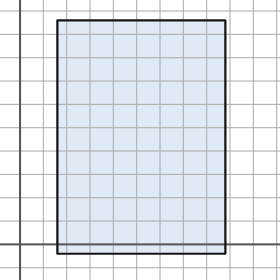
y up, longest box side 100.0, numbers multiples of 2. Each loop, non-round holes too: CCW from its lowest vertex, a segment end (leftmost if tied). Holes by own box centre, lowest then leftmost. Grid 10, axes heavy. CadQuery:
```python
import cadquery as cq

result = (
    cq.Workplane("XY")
    .moveTo(16.0, -4.0)
    .lineTo(88.0, -4.0)
    .lineTo(88.0, 96.0)
    .lineTo(16.0, 96.0)
    .close()
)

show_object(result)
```